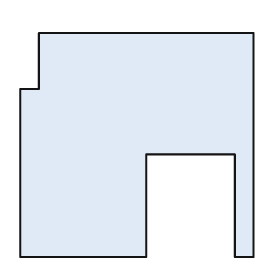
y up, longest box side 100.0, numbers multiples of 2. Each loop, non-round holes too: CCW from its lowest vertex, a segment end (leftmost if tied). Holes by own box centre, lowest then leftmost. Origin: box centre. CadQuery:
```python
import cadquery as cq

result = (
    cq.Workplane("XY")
    .moveTo(-50.0, -48.0)
    .lineTo(4.0, -48.0)
    .lineTo(4.0, -4.0)
    .lineTo(42.0, -4.0)
    .lineTo(42.0, -48.0)
    .lineTo(50.0, -48.0)
    .lineTo(50.0, 48.0)
    .lineTo(-42.0, 48.0)
    .lineTo(-42.0, 24.0)
    .lineTo(-50.0, 24.0)
    .close()
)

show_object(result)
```